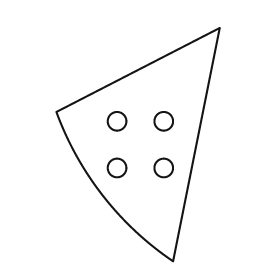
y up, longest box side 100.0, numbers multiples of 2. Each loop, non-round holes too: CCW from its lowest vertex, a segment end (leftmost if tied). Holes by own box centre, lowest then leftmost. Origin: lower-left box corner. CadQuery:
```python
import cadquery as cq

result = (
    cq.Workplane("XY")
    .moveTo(50.0, 0.0)
    .lineTo(70.0, 100.0)
    .lineTo(0.0, 64.0)
    .threePointArc((20.0, 28.0), (50.0, 0.0))
    .close()
    .moveTo(26.0, 40.0)
    .circle(4.0)
    .moveTo(46.0, 40.0)
    .circle(4.0)
    .moveTo(26.0, 60.0)
    .circle(4.0)
    .moveTo(46.0, 60.0)
    .circle(4.0)
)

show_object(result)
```